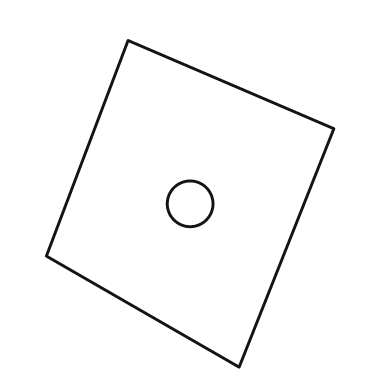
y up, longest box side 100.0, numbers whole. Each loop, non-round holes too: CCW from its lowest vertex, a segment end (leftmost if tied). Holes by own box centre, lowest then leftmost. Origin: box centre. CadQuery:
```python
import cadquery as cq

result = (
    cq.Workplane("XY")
    .moveTo(15.0, -50.0)
    .lineTo(44.0, 23.0)
    .lineTo(-19.0, 50.0)
    .lineTo(-44.0, -16.0)
    .close()
    .moveTo(0.0, 0.0)
    .circle(7.0)
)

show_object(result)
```